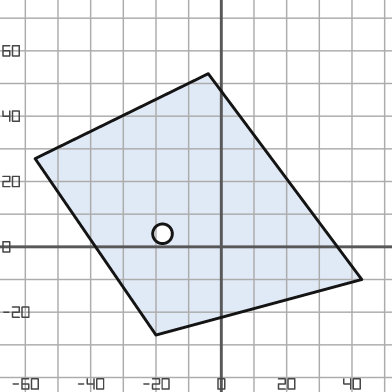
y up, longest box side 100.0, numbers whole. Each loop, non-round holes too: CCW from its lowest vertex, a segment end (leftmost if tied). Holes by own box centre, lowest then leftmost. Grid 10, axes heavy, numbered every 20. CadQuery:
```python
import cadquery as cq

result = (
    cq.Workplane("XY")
    .moveTo(-20.0, -27.0)
    .lineTo(43.0, -10.0)
    .lineTo(-4.0, 53.0)
    .lineTo(-57.0, 27.0)
    .close()
    .moveTo(-18.0, 4.0)
    .circle(3.0)
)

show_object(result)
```